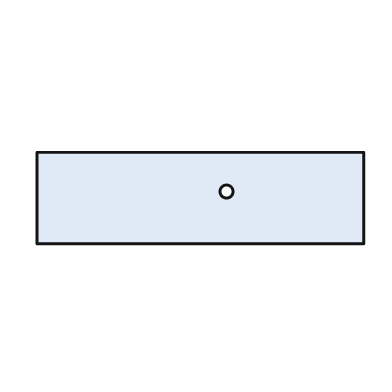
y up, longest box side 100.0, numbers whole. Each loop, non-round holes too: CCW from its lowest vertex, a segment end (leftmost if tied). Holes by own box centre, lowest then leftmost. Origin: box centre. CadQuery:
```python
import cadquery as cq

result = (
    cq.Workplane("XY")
    .moveTo(-50.0, -14.0)
    .lineTo(50.0, -14.0)
    .lineTo(50.0, 14.0)
    .lineTo(-50.0, 14.0)
    .close()
    .moveTo(8.0, 2.0)
    .circle(2.0)
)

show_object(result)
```